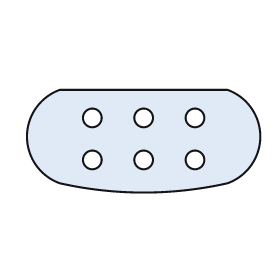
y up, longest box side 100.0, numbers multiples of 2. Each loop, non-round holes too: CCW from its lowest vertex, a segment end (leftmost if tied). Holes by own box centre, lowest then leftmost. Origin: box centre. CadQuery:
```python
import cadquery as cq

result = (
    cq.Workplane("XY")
    .moveTo(-36.0, -18.0)
    .threePointArc((0.0, -22.0), (36.0, -18.0))
    .threePointArc((50.0, 2.0), (36.0, 22.0))
    .lineTo(-36.0, 22.0)
    .threePointArc((-50.0, 2.0), (-36.0, -18.0))
    .close()
    .moveTo(-22.0, -8.0)
    .circle(4.0)
    .moveTo(0.0, -8.0)
    .circle(4.0)
    .moveTo(22.0, -8.0)
    .circle(4.0)
    .moveTo(-22.0, 10.0)
    .circle(4.0)
    .moveTo(0.0, 10.0)
    .circle(4.0)
    .moveTo(22.0, 10.0)
    .circle(4.0)
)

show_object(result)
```